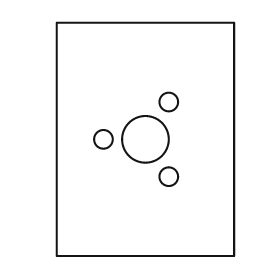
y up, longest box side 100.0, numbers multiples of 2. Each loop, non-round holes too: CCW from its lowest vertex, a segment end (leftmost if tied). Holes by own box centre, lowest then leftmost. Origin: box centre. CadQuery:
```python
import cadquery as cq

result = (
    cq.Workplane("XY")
    .moveTo(-38.0, -50.0)
    .lineTo(38.0, -50.0)
    .lineTo(38.0, 50.0)
    .lineTo(-38.0, 50.0)
    .close()
    .moveTo(10.0, -16.0)
    .circle(4.0)
    .moveTo(-18.0, 0.0)
    .circle(4.0)
    .moveTo(0.0, 0.0)
    .circle(10.0)
    .moveTo(10.0, 16.0)
    .circle(4.0)
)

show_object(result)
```